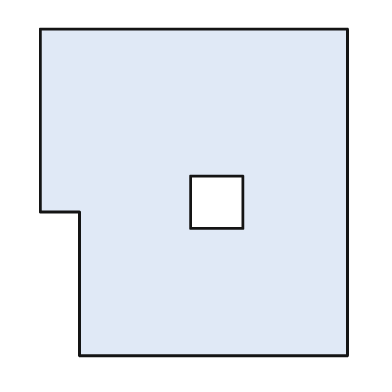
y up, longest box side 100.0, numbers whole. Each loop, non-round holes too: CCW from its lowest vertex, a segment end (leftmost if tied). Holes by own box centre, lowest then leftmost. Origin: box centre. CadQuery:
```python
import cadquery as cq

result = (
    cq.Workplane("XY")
    .moveTo(-35.0, -50.0)
    .lineTo(47.0, -50.0)
    .lineTo(47.0, 50.0)
    .lineTo(-47.0, 50.0)
    .lineTo(-47.0, -6.0)
    .lineTo(-35.0, -6.0)
    .close()
    .moveTo(-1.0, -11.0)
    .lineTo(15.0, -11.0)
    .lineTo(15.0, 5.0)
    .lineTo(-1.0, 5.0)
    .close()
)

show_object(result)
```